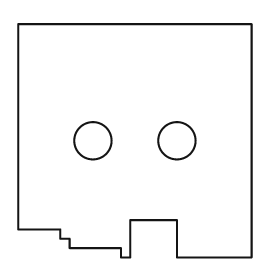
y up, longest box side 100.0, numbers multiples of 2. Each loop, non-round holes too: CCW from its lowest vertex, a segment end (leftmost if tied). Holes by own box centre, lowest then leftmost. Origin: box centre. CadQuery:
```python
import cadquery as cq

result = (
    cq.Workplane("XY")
    .moveTo(-6.0, -50.0)
    .lineTo(-2.0, -50.0)
    .lineTo(-2.0, -34.0)
    .lineTo(18.0, -34.0)
    .lineTo(18.0, -50.0)
    .lineTo(50.0, -50.0)
    .lineTo(50.0, 50.0)
    .lineTo(-50.0, 50.0)
    .lineTo(-50.0, -38.0)
    .lineTo(-32.0, -38.0)
    .lineTo(-32.0, -42.0)
    .lineTo(-28.0, -42.0)
    .lineTo(-28.0, -46.0)
    .lineTo(-6.0, -46.0)
    .close()
    .moveTo(-18.0, 0.0)
    .circle(8.0)
    .moveTo(18.0, 0.0)
    .circle(8.0)
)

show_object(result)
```